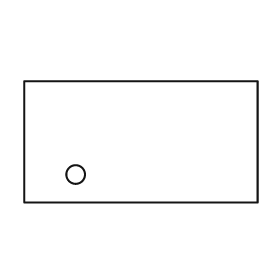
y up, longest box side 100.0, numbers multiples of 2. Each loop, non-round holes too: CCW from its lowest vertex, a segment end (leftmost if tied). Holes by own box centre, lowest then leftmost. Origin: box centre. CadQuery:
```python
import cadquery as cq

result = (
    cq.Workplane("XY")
    .moveTo(-50.0, -26.0)
    .lineTo(50.0, -26.0)
    .lineTo(50.0, 26.0)
    .lineTo(-50.0, 26.0)
    .close()
    .moveTo(-28.0, -14.0)
    .circle(4.0)
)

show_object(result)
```